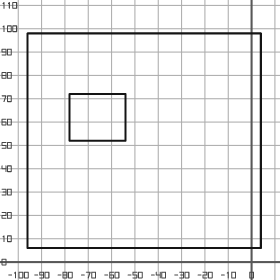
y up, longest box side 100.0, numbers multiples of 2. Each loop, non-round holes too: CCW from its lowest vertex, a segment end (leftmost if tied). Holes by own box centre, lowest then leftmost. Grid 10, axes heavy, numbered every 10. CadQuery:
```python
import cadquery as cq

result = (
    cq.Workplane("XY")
    .moveTo(-96.0, 6.0)
    .lineTo(4.0, 6.0)
    .lineTo(4.0, 98.0)
    .lineTo(-96.0, 98.0)
    .close()
    .moveTo(-78.0, 52.0)
    .lineTo(-54.0, 52.0)
    .lineTo(-54.0, 72.0)
    .lineTo(-78.0, 72.0)
    .close()
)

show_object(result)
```